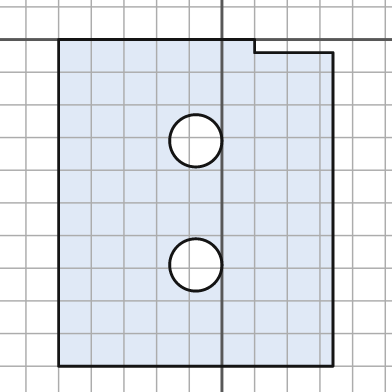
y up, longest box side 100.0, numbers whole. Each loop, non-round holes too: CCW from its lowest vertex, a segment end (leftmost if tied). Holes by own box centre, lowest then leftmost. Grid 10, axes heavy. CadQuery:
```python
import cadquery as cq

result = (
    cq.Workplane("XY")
    .moveTo(-50.0, -100.0)
    .lineTo(34.0, -100.0)
    .lineTo(34.0, -4.0)
    .lineTo(10.0, -4.0)
    .lineTo(10.0, 0.0)
    .lineTo(-50.0, 0.0)
    .close()
    .moveTo(-8.0, -69.0)
    .circle(8.0)
    .moveTo(-8.0, -31.0)
    .circle(8.0)
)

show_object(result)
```